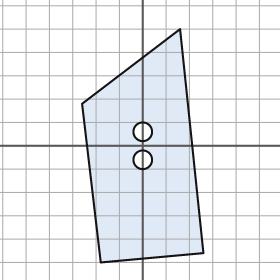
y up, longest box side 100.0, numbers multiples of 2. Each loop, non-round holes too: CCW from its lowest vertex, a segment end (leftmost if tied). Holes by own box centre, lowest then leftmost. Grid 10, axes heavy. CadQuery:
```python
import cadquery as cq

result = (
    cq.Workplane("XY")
    .moveTo(-18.0, -50.0)
    .lineTo(26.0, -46.0)
    .lineTo(16.0, 50.0)
    .lineTo(-26.0, 18.0)
    .close()
    .moveTo(0.0, -6.0)
    .circle(4.0)
    .moveTo(0.0, 6.0)
    .circle(4.0)
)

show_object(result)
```